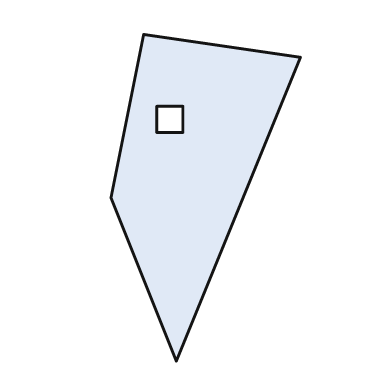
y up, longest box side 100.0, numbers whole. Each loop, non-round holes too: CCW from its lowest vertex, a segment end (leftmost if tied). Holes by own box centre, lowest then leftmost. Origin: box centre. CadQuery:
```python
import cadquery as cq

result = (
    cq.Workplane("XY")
    .moveTo(-9.0, -50.0)
    .lineTo(29.0, 43.0)
    .lineTo(-19.0, 50.0)
    .lineTo(-29.0, 0.0)
    .close()
    .moveTo(-15.0, 20.0)
    .lineTo(-7.0, 20.0)
    .lineTo(-7.0, 28.0)
    .lineTo(-15.0, 28.0)
    .close()
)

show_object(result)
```